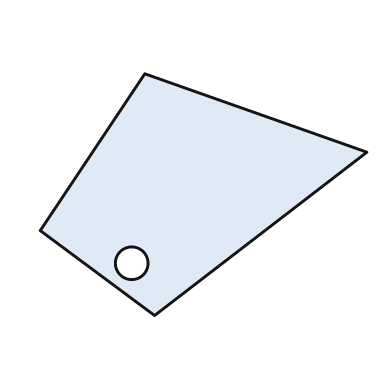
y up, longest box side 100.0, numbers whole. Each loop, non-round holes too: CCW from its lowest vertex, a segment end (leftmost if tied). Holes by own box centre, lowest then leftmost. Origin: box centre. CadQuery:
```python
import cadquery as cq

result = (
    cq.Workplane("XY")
    .moveTo(-15.0, -37.0)
    .lineTo(50.0, 13.0)
    .lineTo(-18.0, 37.0)
    .lineTo(-50.0, -11.0)
    .close()
    .moveTo(-22.0, -21.0)
    .circle(5.0)
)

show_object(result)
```